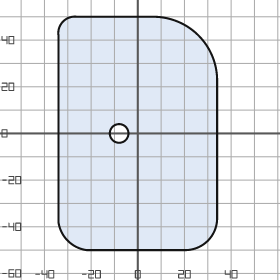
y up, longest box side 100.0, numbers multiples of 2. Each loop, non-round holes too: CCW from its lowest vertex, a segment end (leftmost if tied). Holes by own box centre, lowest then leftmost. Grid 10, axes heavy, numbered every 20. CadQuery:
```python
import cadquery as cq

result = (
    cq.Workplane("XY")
    .moveTo(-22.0, -50.0)
    .lineTo(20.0, -50.0)
    .threePointArc((30.0, -46.0), (34.0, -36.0))
    .lineTo(34.0, 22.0)
    .threePointArc((26.0, 42.0), (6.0, 50.0))
    .lineTo(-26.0, 50.0)
    .threePointArc((-32.0, 48.0), (-34.0, 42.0))
    .lineTo(-34.0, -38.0)
    .threePointArc((-30.0, -46.0), (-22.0, -50.0))
    .close()
    .moveTo(-8.0, 0.0)
    .circle(4.0)
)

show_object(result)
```